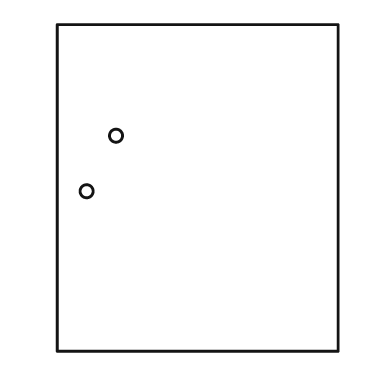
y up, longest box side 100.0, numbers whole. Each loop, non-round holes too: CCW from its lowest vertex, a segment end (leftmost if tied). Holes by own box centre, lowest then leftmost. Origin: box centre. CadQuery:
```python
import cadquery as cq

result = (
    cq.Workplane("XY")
    .moveTo(-43.0, -50.0)
    .lineTo(43.0, -50.0)
    .lineTo(43.0, 50.0)
    .lineTo(-43.0, 50.0)
    .close()
    .moveTo(-34.0, -1.0)
    .circle(2.0)
    .moveTo(-25.0, 16.0)
    .circle(2.0)
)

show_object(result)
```